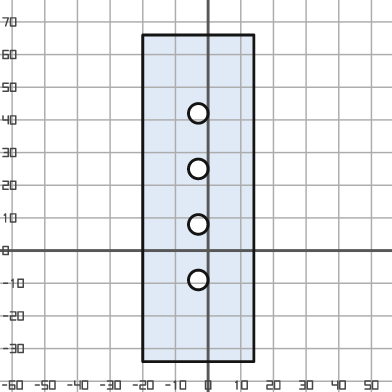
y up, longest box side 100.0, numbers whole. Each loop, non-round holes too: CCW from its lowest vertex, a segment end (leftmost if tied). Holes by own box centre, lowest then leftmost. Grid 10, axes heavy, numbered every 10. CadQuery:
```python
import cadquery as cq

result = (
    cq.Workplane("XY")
    .moveTo(-20.0, -34.0)
    .lineTo(14.0, -34.0)
    .lineTo(14.0, 66.0)
    .lineTo(-20.0, 66.0)
    .close()
    .moveTo(-3.0, -9.0)
    .circle(3.0)
    .moveTo(-3.0, 8.0)
    .circle(3.0)
    .moveTo(-3.0, 25.0)
    .circle(3.0)
    .moveTo(-3.0, 42.0)
    .circle(3.0)
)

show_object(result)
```